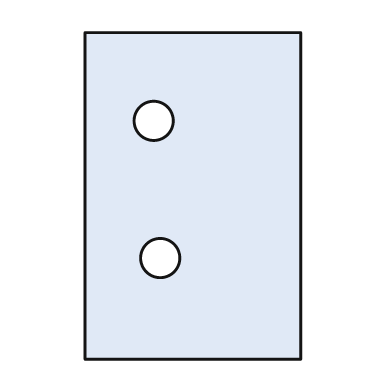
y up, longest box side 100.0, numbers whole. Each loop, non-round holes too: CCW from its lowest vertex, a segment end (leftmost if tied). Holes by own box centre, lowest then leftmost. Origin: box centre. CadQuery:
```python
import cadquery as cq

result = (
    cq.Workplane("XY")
    .moveTo(-33.0, -50.0)
    .lineTo(33.0, -50.0)
    .lineTo(33.0, 50.0)
    .lineTo(-33.0, 50.0)
    .close()
    .moveTo(-10.0, -19.0)
    .circle(6.0)
    .moveTo(-12.0, 23.0)
    .circle(6.0)
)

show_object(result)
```